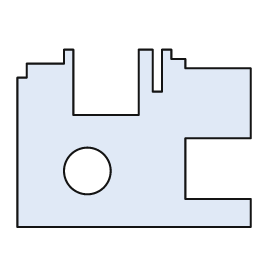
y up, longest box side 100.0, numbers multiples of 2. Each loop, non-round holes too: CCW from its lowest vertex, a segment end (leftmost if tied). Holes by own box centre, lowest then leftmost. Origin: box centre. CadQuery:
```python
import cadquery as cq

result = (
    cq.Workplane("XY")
    .moveTo(-50.0, -38.0)
    .lineTo(50.0, -38.0)
    .lineTo(50.0, -26.0)
    .lineTo(22.0, -26.0)
    .lineTo(22.0, 0.0)
    .lineTo(50.0, 0.0)
    .lineTo(50.0, 30.0)
    .lineTo(22.0, 30.0)
    .lineTo(22.0, 34.0)
    .lineTo(16.0, 34.0)
    .lineTo(16.0, 38.0)
    .lineTo(12.0, 38.0)
    .lineTo(12.0, 20.0)
    .lineTo(8.0, 20.0)
    .lineTo(8.0, 38.0)
    .lineTo(2.0, 38.0)
    .lineTo(2.0, 10.0)
    .lineTo(-26.0, 10.0)
    .lineTo(-26.0, 38.0)
    .lineTo(-30.0, 38.0)
    .lineTo(-30.0, 32.0)
    .lineTo(-46.0, 32.0)
    .lineTo(-46.0, 26.0)
    .lineTo(-50.0, 26.0)
    .close()
    .moveTo(-20.0, -14.0)
    .circle(10.0)
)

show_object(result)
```